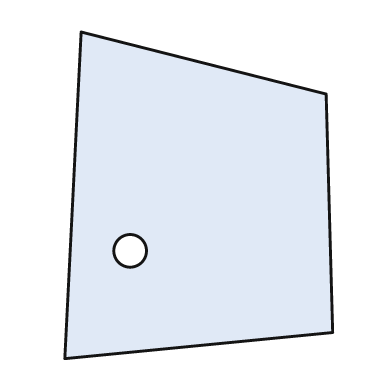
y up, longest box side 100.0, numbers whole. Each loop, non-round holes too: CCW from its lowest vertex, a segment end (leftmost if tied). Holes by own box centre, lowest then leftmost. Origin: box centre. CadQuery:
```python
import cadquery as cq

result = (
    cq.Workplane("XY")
    .moveTo(-41.0, -50.0)
    .lineTo(41.0, -42.0)
    .lineTo(39.0, 31.0)
    .lineTo(-36.0, 50.0)
    .close()
    .moveTo(-21.0, -17.0)
    .circle(5.0)
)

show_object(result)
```